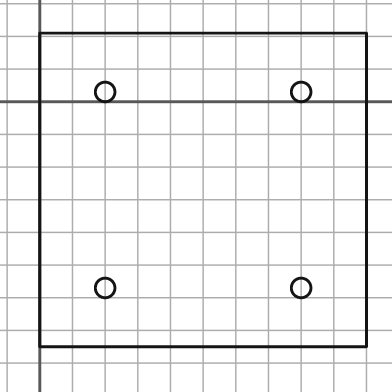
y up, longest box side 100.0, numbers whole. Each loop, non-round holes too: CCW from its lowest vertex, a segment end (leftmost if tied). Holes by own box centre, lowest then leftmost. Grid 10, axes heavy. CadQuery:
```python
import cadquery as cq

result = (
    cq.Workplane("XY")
    .moveTo(0.0, -75.0)
    .lineTo(100.0, -75.0)
    .lineTo(100.0, 21.0)
    .lineTo(0.0, 21.0)
    .close()
    .moveTo(20.0, -57.0)
    .circle(3.0)
    .moveTo(80.0, -57.0)
    .circle(3.0)
    .moveTo(20.0, 3.0)
    .circle(3.0)
    .moveTo(80.0, 3.0)
    .circle(3.0)
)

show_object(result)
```